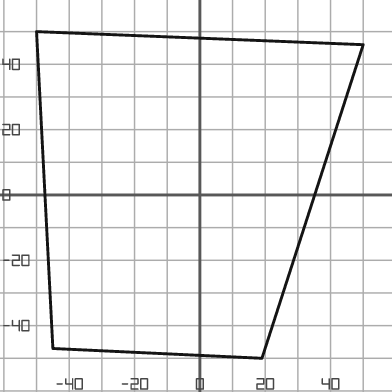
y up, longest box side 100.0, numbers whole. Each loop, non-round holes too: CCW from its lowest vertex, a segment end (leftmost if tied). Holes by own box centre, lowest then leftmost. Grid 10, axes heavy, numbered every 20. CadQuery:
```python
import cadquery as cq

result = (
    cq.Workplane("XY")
    .moveTo(19.0, -50.0)
    .lineTo(50.0, 46.0)
    .lineTo(-50.0, 50.0)
    .lineTo(-45.0, -47.0)
    .close()
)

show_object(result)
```